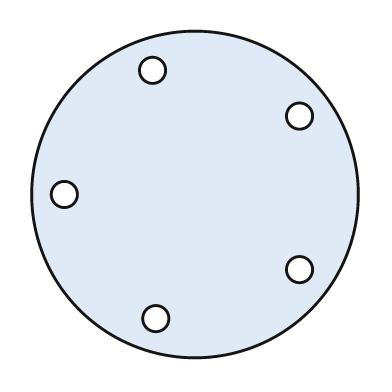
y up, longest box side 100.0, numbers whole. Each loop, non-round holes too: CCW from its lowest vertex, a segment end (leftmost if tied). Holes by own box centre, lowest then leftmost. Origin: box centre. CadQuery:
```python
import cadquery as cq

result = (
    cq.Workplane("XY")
    .moveTo(0.0, 0.0)
    .circle(50.0)
    .moveTo(-12.0, -38.0)
    .circle(4.0)
    .moveTo(32.0, -23.0)
    .circle(4.0)
    .moveTo(-40.0, 0.0)
    .circle(4.0)
    .moveTo(32.0, 24.0)
    .circle(4.0)
    .moveTo(-13.0, 38.0)
    .circle(4.0)
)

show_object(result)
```